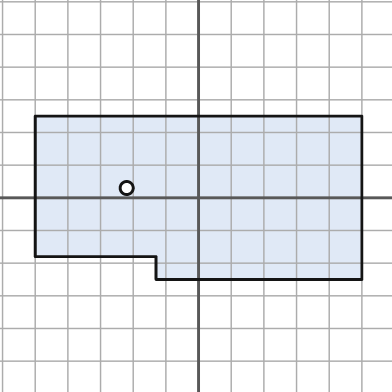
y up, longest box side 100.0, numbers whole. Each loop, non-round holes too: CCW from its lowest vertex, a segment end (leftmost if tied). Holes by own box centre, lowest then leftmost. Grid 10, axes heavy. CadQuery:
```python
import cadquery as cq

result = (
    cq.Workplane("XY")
    .moveTo(-13.0, -25.0)
    .lineTo(50.0, -25.0)
    .lineTo(50.0, 25.0)
    .lineTo(-50.0, 25.0)
    .lineTo(-50.0, -18.0)
    .lineTo(-13.0, -18.0)
    .close()
    .moveTo(-22.0, 3.0)
    .circle(2.0)
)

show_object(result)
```